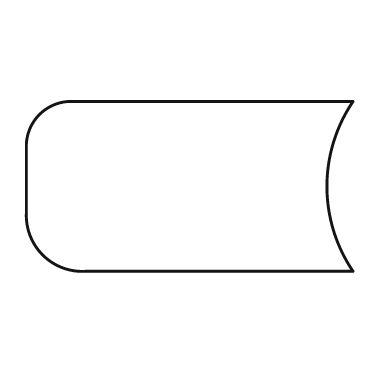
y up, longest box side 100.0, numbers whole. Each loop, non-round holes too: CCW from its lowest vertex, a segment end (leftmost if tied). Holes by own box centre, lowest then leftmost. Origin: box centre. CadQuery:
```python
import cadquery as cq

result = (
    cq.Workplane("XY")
    .moveTo(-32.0, -26.0)
    .lineTo(50.0, -26.0)
    .threePointArc((42.0, 0.0), (50.0, 26.0))
    .lineTo(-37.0, 26.0)
    .threePointArc((-46.0, 22.0), (-50.0, 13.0))
    .lineTo(-50.0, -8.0)
    .threePointArc((-45.0, -21.0), (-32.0, -26.0))
    .close()
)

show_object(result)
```